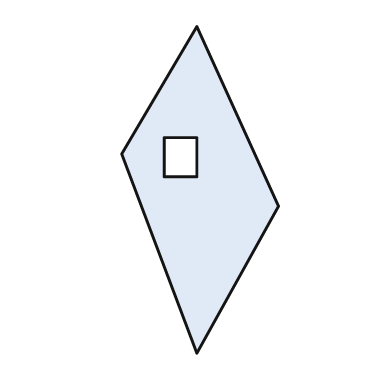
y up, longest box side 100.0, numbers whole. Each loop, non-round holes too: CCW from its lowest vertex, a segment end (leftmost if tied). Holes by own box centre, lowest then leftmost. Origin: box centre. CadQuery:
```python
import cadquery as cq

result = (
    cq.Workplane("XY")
    .moveTo(-1.0, -50.0)
    .lineTo(24.0, -5.0)
    .lineTo(-1.0, 50.0)
    .lineTo(-24.0, 11.0)
    .close()
    .moveTo(-11.0, 4.0)
    .lineTo(-1.0, 4.0)
    .lineTo(-1.0, 16.0)
    .lineTo(-11.0, 16.0)
    .close()
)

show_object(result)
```